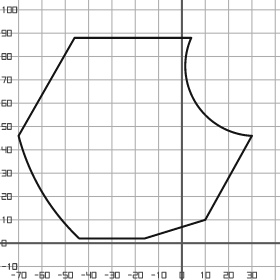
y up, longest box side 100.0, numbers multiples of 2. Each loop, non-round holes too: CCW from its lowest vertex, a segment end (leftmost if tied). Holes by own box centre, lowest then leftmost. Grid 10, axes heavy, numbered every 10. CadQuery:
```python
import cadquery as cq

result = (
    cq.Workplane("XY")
    .moveTo(-44.0, 2.0)
    .lineTo(-16.0, 2.0)
    .lineTo(10.0, 10.0)
    .lineTo(30.0, 46.0)
    .threePointArc((6.0, 60.0), (4.0, 88.0))
    .lineTo(-46.0, 88.0)
    .lineTo(-70.0, 46.0)
    .threePointArc((-60.0, 22.0), (-44.0, 2.0))
    .close()
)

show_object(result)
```